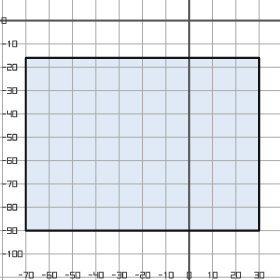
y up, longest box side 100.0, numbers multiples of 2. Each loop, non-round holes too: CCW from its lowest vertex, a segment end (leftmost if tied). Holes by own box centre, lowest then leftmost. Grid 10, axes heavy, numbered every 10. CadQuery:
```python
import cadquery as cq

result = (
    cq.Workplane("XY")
    .moveTo(-70.0, -90.0)
    .lineTo(30.0, -90.0)
    .lineTo(30.0, -16.0)
    .lineTo(-70.0, -16.0)
    .close()
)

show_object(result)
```